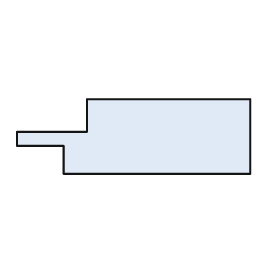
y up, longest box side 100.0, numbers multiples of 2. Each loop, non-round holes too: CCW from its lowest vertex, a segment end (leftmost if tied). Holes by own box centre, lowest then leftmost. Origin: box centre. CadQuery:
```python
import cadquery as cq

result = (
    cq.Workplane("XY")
    .moveTo(-30.0, -16.0)
    .lineTo(50.0, -16.0)
    .lineTo(50.0, 16.0)
    .lineTo(-20.0, 16.0)
    .lineTo(-20.0, 2.0)
    .lineTo(-50.0, 2.0)
    .lineTo(-50.0, -4.0)
    .lineTo(-30.0, -4.0)
    .close()
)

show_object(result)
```